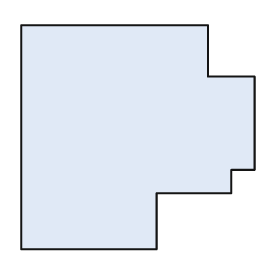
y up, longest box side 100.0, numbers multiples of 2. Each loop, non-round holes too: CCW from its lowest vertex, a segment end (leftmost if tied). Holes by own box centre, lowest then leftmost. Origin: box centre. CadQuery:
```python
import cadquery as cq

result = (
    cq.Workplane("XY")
    .moveTo(-50.0, -48.0)
    .lineTo(8.0, -48.0)
    .lineTo(8.0, -24.0)
    .lineTo(40.0, -24.0)
    .lineTo(40.0, -14.0)
    .lineTo(50.0, -14.0)
    .lineTo(50.0, 26.0)
    .lineTo(30.0, 26.0)
    .lineTo(30.0, 48.0)
    .lineTo(-50.0, 48.0)
    .close()
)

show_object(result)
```